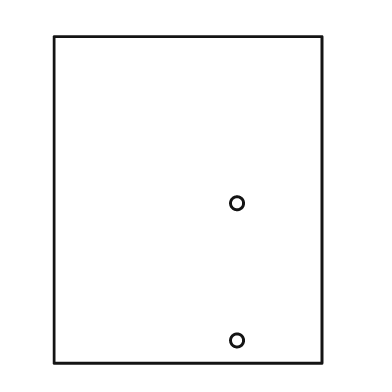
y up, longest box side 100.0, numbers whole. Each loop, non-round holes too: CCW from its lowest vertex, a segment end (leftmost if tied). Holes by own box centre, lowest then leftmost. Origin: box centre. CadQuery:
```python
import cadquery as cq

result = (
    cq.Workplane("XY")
    .moveTo(-41.0, -50.0)
    .lineTo(41.0, -50.0)
    .lineTo(41.0, 50.0)
    .lineTo(-41.0, 50.0)
    .close()
    .moveTo(15.0, -43.0)
    .circle(2.0)
    .moveTo(15.0, -1.0)
    .circle(2.0)
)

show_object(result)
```